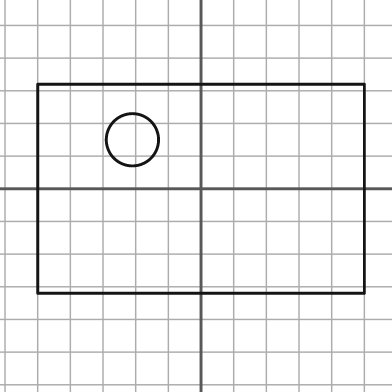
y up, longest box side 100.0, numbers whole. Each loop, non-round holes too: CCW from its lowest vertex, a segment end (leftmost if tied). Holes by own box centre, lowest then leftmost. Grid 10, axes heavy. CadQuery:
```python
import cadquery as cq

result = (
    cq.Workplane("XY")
    .moveTo(-50.0, -32.0)
    .lineTo(50.0, -32.0)
    .lineTo(50.0, 32.0)
    .lineTo(-50.0, 32.0)
    .close()
    .moveTo(-21.0, 15.0)
    .circle(8.0)
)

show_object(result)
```